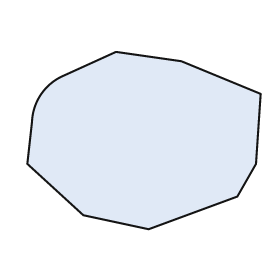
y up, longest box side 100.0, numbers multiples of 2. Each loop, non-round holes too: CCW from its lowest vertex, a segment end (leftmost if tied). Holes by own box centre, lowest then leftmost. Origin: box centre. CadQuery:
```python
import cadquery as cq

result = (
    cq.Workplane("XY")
    .moveTo(2.0, -38.0)
    .lineTo(40.0, -24.0)
    .lineTo(48.0, -10.0)
    .lineTo(50.0, 20.0)
    .lineTo(16.0, 34.0)
    .lineTo(-12.0, 38.0)
    .lineTo(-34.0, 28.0)
    .threePointArc((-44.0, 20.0), (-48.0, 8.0))
    .lineTo(-50.0, -10.0)
    .lineTo(-26.0, -32.0)
    .close()
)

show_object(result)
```